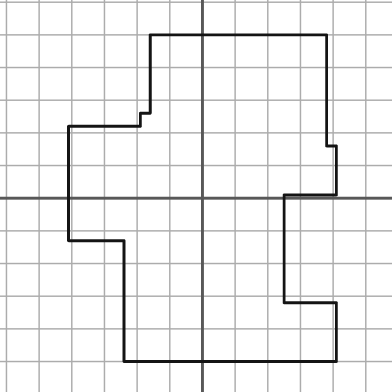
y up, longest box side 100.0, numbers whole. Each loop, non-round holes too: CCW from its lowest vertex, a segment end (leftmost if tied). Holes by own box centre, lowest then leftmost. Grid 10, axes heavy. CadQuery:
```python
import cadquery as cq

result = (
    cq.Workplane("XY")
    .moveTo(-24.0, -50.0)
    .lineTo(41.0, -50.0)
    .lineTo(41.0, -32.0)
    .lineTo(25.0, -32.0)
    .lineTo(25.0, 1.0)
    .lineTo(41.0, 1.0)
    .lineTo(41.0, 16.0)
    .lineTo(38.0, 16.0)
    .lineTo(38.0, 50.0)
    .lineTo(-16.0, 50.0)
    .lineTo(-16.0, 26.0)
    .lineTo(-19.0, 26.0)
    .lineTo(-19.0, 22.0)
    .lineTo(-41.0, 22.0)
    .lineTo(-41.0, -13.0)
    .lineTo(-24.0, -13.0)
    .close()
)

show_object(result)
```